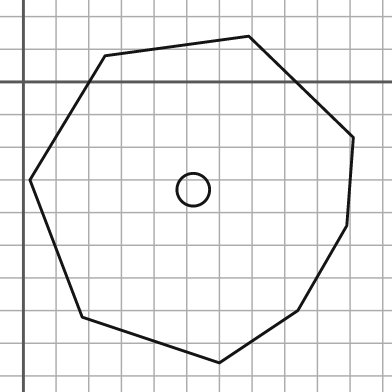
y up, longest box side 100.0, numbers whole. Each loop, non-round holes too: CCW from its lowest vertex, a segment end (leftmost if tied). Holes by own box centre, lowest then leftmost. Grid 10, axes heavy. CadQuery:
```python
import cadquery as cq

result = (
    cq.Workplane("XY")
    .moveTo(60.0, -86.0)
    .lineTo(84.0, -70.0)
    .lineTo(99.0, -44.0)
    .lineTo(101.0, -17.0)
    .lineTo(69.0, 14.0)
    .lineTo(25.0, 8.0)
    .lineTo(2.0, -30.0)
    .lineTo(18.0, -72.0)
    .close()
    .moveTo(52.0, -33.0)
    .circle(5.0)
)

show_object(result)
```